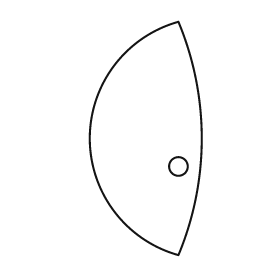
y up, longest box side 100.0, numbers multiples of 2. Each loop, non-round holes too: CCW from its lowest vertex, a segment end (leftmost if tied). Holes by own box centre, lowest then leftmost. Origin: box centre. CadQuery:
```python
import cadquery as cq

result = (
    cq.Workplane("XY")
    .moveTo(14.0, -50.0)
    .threePointArc((24.0, 0.0), (14.0, 50.0))
    .threePointArc((-24.0, 0.0), (14.0, -50.0))
    .close()
    .moveTo(14.0, -12.0)
    .circle(4.0)
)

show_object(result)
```